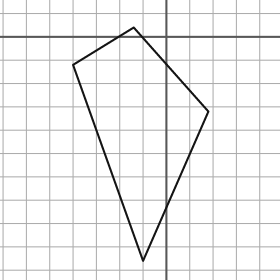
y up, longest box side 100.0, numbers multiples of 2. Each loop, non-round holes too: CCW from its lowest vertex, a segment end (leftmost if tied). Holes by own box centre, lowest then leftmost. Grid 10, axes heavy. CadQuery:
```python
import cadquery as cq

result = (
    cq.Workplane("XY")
    .moveTo(-10.0, -96.0)
    .lineTo(18.0, -32.0)
    .lineTo(-14.0, 4.0)
    .lineTo(-40.0, -12.0)
    .close()
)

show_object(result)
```